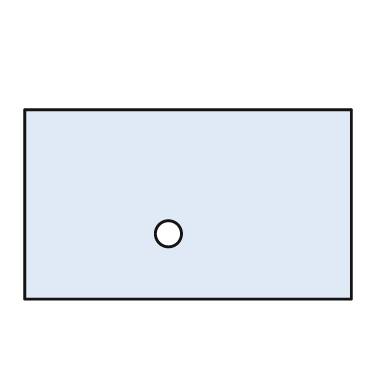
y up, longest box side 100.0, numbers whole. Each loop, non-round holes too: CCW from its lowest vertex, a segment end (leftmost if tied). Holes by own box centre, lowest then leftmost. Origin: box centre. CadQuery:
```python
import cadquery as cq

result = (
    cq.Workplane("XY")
    .moveTo(-50.0, -29.0)
    .lineTo(50.0, -29.0)
    .lineTo(50.0, 29.0)
    .lineTo(-50.0, 29.0)
    .close()
    .moveTo(-6.0, -9.0)
    .circle(4.0)
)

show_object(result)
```